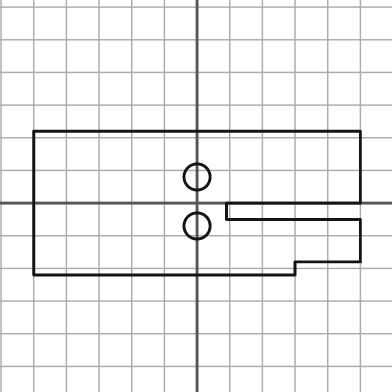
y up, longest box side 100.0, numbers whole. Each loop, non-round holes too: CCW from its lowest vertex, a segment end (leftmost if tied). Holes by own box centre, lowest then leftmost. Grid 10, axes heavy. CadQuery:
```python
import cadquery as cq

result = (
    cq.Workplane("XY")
    .moveTo(-50.0, -22.0)
    .lineTo(30.0, -22.0)
    .lineTo(30.0, -18.0)
    .lineTo(50.0, -18.0)
    .lineTo(50.0, -5.0)
    .lineTo(9.0, -5.0)
    .lineTo(9.0, 0.0)
    .lineTo(50.0, 0.0)
    .lineTo(50.0, 22.0)
    .lineTo(-50.0, 22.0)
    .close()
    .moveTo(0.0, -7.0)
    .circle(4.0)
    .moveTo(0.0, 8.0)
    .circle(4.0)
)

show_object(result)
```